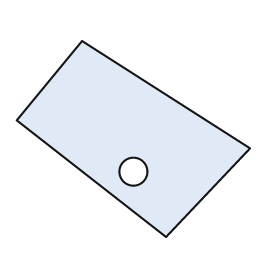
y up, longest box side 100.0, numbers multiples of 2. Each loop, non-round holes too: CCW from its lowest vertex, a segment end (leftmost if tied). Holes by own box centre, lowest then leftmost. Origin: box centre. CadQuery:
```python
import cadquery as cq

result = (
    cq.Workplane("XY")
    .moveTo(14.0, -42.0)
    .lineTo(50.0, -4.0)
    .lineTo(-22.0, 42.0)
    .lineTo(-50.0, 8.0)
    .close()
    .moveTo(0.0, -14.0)
    .circle(6.0)
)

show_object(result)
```